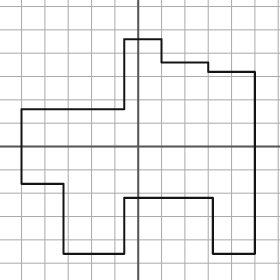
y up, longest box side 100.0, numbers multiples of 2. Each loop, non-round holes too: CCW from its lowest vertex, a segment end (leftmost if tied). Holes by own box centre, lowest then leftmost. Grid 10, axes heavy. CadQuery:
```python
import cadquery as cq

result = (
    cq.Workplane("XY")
    .moveTo(-32.0, -46.0)
    .lineTo(-6.0, -46.0)
    .lineTo(-6.0, -22.0)
    .lineTo(32.0, -22.0)
    .lineTo(32.0, -46.0)
    .lineTo(50.0, -46.0)
    .lineTo(50.0, 32.0)
    .lineTo(30.0, 32.0)
    .lineTo(30.0, 36.0)
    .lineTo(10.0, 36.0)
    .lineTo(10.0, 46.0)
    .lineTo(-6.0, 46.0)
    .lineTo(-6.0, 16.0)
    .lineTo(-50.0, 16.0)
    .lineTo(-50.0, -16.0)
    .lineTo(-32.0, -16.0)
    .close()
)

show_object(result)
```